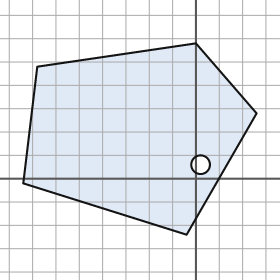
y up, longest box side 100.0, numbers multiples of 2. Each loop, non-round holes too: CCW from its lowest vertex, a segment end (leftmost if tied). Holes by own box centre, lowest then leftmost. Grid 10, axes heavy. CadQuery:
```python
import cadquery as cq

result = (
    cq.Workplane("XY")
    .moveTo(-4.0, -24.0)
    .lineTo(26.0, 28.0)
    .lineTo(0.0, 58.0)
    .lineTo(-68.0, 48.0)
    .lineTo(-74.0, -2.0)
    .close()
    .moveTo(2.0, 6.0)
    .circle(4.0)
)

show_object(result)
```